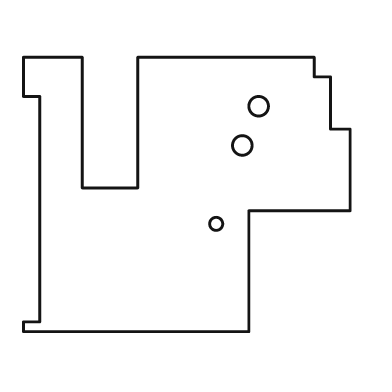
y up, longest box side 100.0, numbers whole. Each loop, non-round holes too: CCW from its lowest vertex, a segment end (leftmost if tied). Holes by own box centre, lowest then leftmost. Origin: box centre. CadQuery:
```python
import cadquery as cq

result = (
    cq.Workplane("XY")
    .moveTo(-50.0, -42.0)
    .lineTo(19.0, -42.0)
    .lineTo(19.0, -5.0)
    .lineTo(50.0, -5.0)
    .lineTo(50.0, 20.0)
    .lineTo(44.0, 20.0)
    .lineTo(44.0, 36.0)
    .lineTo(39.0, 36.0)
    .lineTo(39.0, 42.0)
    .lineTo(-15.0, 42.0)
    .lineTo(-15.0, 2.0)
    .lineTo(-32.0, 2.0)
    .lineTo(-32.0, 42.0)
    .lineTo(-50.0, 42.0)
    .lineTo(-50.0, 30.0)
    .lineTo(-45.0, 30.0)
    .lineTo(-45.0, -39.0)
    .lineTo(-50.0, -39.0)
    .close()
    .moveTo(9.0, -9.0)
    .circle(2.0)
    .moveTo(17.0, 15.0)
    .circle(3.0)
    .moveTo(22.0, 27.0)
    .circle(3.0)
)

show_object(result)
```